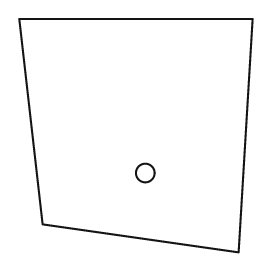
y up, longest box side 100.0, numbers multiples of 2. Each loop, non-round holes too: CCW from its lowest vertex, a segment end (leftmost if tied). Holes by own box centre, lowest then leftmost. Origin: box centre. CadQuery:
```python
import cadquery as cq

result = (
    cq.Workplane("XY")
    .moveTo(44.0, -50.0)
    .lineTo(50.0, 50.0)
    .lineTo(-50.0, 50.0)
    .lineTo(-40.0, -38.0)
    .close()
    .moveTo(4.0, -16.0)
    .circle(4.0)
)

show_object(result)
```